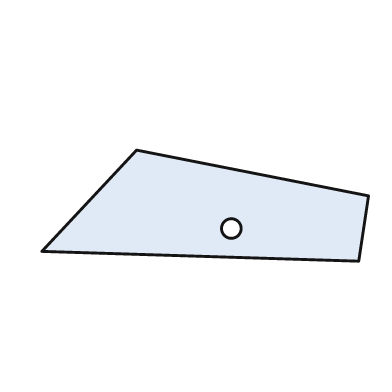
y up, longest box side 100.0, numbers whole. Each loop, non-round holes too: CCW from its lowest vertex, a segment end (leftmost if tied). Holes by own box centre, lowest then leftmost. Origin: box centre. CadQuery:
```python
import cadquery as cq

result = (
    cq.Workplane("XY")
    .moveTo(47.0, -17.0)
    .lineTo(50.0, 3.0)
    .lineTo(-21.0, 17.0)
    .lineTo(-50.0, -14.0)
    .close()
    .moveTo(8.0, -7.0)
    .circle(3.0)
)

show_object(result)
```